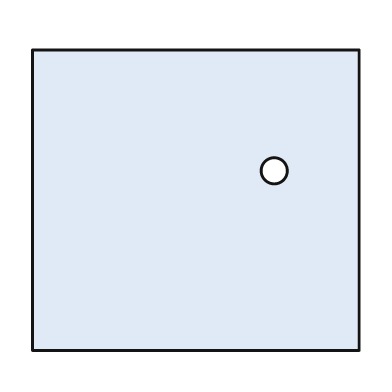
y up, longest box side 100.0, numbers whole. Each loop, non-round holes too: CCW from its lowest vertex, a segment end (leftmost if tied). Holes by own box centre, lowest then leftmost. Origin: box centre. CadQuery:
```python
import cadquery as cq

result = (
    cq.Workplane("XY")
    .moveTo(-50.0, -46.0)
    .lineTo(50.0, -46.0)
    .lineTo(50.0, 46.0)
    .lineTo(-50.0, 46.0)
    .close()
    .moveTo(24.0, 9.0)
    .circle(4.0)
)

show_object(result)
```